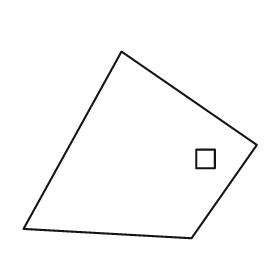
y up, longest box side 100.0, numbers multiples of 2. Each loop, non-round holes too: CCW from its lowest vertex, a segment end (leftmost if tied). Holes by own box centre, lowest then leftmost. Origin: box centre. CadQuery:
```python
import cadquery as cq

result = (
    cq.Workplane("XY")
    .moveTo(22.0, -40.0)
    .lineTo(50.0, 0.0)
    .lineTo(-8.0, 40.0)
    .lineTo(-50.0, -36.0)
    .close()
    .moveTo(24.0, -10.0)
    .lineTo(32.0, -10.0)
    .lineTo(32.0, -2.0)
    .lineTo(24.0, -2.0)
    .close()
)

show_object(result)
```